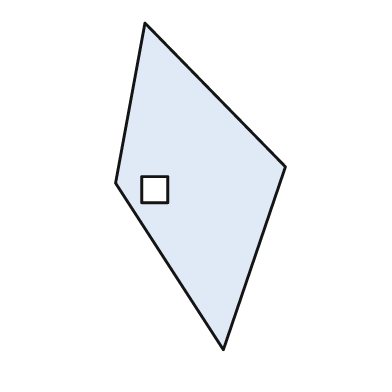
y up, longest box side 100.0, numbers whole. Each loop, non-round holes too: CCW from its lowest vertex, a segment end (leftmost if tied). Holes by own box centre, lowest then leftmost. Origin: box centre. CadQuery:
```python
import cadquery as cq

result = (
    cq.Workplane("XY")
    .moveTo(7.0, -50.0)
    .lineTo(26.0, 6.0)
    .lineTo(-17.0, 50.0)
    .lineTo(-26.0, 1.0)
    .close()
    .moveTo(-18.0, -5.0)
    .lineTo(-10.0, -5.0)
    .lineTo(-10.0, 3.0)
    .lineTo(-18.0, 3.0)
    .close()
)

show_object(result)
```